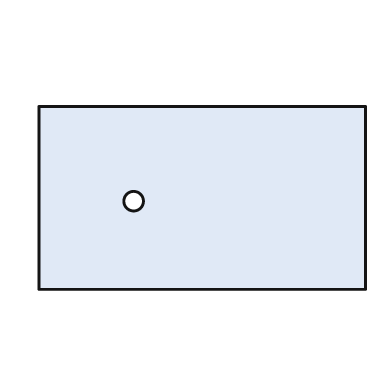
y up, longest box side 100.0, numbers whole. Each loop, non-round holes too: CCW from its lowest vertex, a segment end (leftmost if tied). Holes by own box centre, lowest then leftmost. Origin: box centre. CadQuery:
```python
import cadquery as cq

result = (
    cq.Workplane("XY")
    .moveTo(-50.0, -28.0)
    .lineTo(50.0, -28.0)
    .lineTo(50.0, 28.0)
    .lineTo(-50.0, 28.0)
    .close()
    .moveTo(-21.0, -1.0)
    .circle(3.0)
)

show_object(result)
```